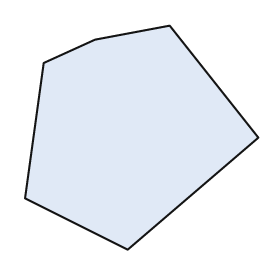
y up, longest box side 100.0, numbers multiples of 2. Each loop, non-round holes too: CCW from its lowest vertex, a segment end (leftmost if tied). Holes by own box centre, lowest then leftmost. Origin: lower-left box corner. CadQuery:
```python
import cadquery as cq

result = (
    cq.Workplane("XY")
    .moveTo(44.0, 0.0)
    .lineTo(100.0, 48.0)
    .lineTo(62.0, 96.0)
    .lineTo(30.0, 90.0)
    .lineTo(8.0, 80.0)
    .lineTo(0.0, 22.0)
    .close()
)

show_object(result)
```